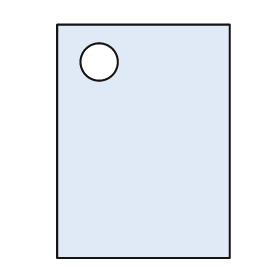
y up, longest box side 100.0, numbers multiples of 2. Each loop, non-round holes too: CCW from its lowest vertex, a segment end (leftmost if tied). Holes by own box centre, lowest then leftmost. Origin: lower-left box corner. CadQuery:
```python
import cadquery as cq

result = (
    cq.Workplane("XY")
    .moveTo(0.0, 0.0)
    .lineTo(74.0, 0.0)
    .lineTo(74.0, 100.0)
    .lineTo(0.0, 100.0)
    .close()
    .moveTo(18.0, 84.0)
    .circle(8.0)
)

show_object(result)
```